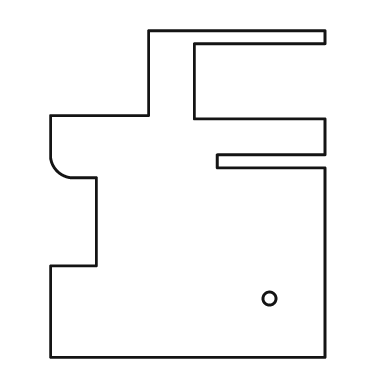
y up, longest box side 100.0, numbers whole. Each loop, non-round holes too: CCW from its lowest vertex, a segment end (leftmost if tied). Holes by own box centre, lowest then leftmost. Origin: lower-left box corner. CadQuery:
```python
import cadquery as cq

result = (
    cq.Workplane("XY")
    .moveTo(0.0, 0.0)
    .lineTo(84.0, 0.0)
    .lineTo(84.0, 58.0)
    .lineTo(51.0, 58.0)
    .lineTo(51.0, 62.0)
    .lineTo(84.0, 62.0)
    .lineTo(84.0, 73.0)
    .lineTo(44.0, 73.0)
    .lineTo(44.0, 96.0)
    .lineTo(84.0, 96.0)
    .lineTo(84.0, 100.0)
    .lineTo(30.0, 100.0)
    .lineTo(30.0, 74.0)
    .lineTo(0.0, 74.0)
    .lineTo(0.0, 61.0)
    .threePointArc((2.0, 57.0), (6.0, 55.0))
    .lineTo(14.0, 55.0)
    .lineTo(14.0, 28.0)
    .lineTo(0.0, 28.0)
    .close()
    .moveTo(67.0, 18.0)
    .circle(2.0)
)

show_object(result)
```